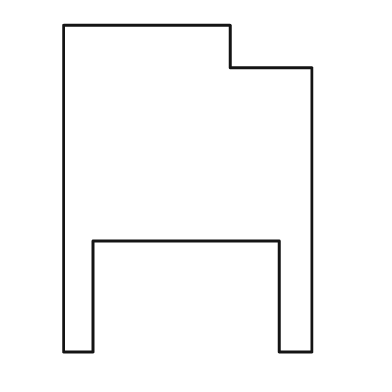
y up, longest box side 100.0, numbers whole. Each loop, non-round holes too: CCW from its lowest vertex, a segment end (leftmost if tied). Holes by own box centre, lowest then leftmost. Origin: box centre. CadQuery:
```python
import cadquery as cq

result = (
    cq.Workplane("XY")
    .moveTo(-38.0, -50.0)
    .lineTo(-29.0, -50.0)
    .lineTo(-29.0, -16.0)
    .lineTo(28.0, -16.0)
    .lineTo(28.0, -50.0)
    .lineTo(38.0, -50.0)
    .lineTo(38.0, 37.0)
    .lineTo(13.0, 37.0)
    .lineTo(13.0, 50.0)
    .lineTo(-38.0, 50.0)
    .close()
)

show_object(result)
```